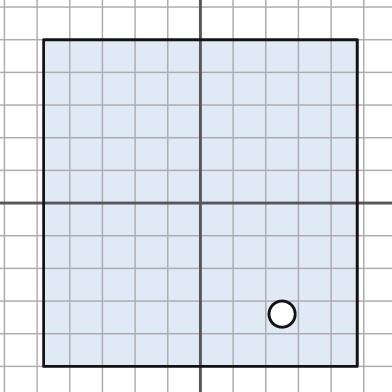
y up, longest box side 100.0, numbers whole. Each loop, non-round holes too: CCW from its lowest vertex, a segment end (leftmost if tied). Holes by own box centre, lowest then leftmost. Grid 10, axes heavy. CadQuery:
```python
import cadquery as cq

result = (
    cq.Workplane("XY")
    .moveTo(-48.0, -50.0)
    .lineTo(48.0, -50.0)
    .lineTo(48.0, 50.0)
    .lineTo(-48.0, 50.0)
    .close()
    .moveTo(25.0, -34.0)
    .circle(4.0)
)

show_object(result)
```